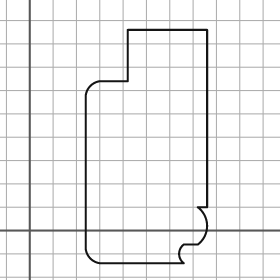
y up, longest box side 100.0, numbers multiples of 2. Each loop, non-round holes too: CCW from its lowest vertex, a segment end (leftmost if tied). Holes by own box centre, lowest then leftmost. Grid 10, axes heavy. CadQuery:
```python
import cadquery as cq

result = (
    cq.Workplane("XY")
    .moveTo(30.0, -14.0)
    .lineTo(66.0, -14.0)
    .threePointArc((64.0, -10.0), (66.0, -6.0))
    .lineTo(72.0, -6.0)
    .threePointArc((76.0, 2.0), (72.0, 10.0))
    .lineTo(76.0, 10.0)
    .lineTo(76.0, 86.0)
    .lineTo(42.0, 86.0)
    .lineTo(42.0, 64.0)
    .lineTo(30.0, 64.0)
    .threePointArc((26.0, 62.0), (24.0, 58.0))
    .lineTo(24.0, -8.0)
    .threePointArc((26.0, -12.0), (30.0, -14.0))
    .close()
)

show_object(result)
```